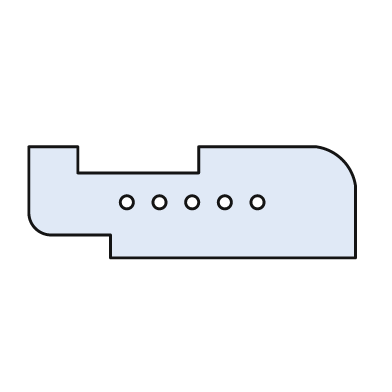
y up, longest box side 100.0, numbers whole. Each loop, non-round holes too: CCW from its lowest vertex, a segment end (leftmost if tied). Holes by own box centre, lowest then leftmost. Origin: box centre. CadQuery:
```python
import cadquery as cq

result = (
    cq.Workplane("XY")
    .moveTo(-25.0, -17.0)
    .lineTo(50.0, -17.0)
    .lineTo(50.0, 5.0)
    .threePointArc((46.0, 13.0), (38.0, 17.0))
    .lineTo(2.0, 17.0)
    .lineTo(2.0, 9.0)
    .lineTo(-35.0, 9.0)
    .lineTo(-35.0, 17.0)
    .lineTo(-50.0, 17.0)
    .lineTo(-50.0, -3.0)
    .threePointArc((-48.0, -8.0), (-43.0, -10.0))
    .lineTo(-25.0, -10.0)
    .close()
    .moveTo(-20.0, 0.0)
    .circle(2.0)
    .moveTo(-10.0, 0.0)
    .circle(2.0)
    .moveTo(0.0, 0.0)
    .circle(2.0)
    .moveTo(10.0, 0.0)
    .circle(2.0)
    .moveTo(20.0, 0.0)
    .circle(2.0)
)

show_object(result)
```